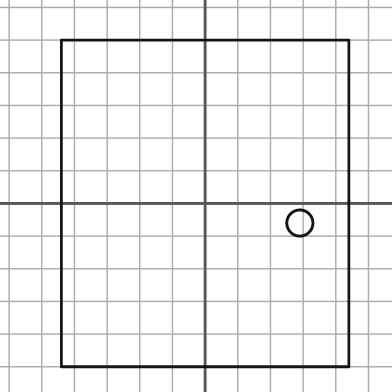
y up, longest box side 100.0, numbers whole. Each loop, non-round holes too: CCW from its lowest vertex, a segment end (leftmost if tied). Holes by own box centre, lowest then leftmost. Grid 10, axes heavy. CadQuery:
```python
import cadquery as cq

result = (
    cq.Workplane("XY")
    .moveTo(-44.0, -50.0)
    .lineTo(44.0, -50.0)
    .lineTo(44.0, 50.0)
    .lineTo(-44.0, 50.0)
    .close()
    .moveTo(29.0, -6.0)
    .circle(4.0)
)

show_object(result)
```